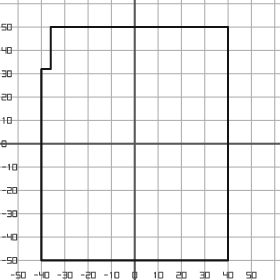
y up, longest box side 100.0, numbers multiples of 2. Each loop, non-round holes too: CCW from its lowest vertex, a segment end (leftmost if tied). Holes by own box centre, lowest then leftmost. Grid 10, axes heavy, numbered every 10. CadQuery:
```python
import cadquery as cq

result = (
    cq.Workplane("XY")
    .moveTo(-40.0, -50.0)
    .lineTo(40.0, -50.0)
    .lineTo(40.0, 50.0)
    .lineTo(-36.0, 50.0)
    .lineTo(-36.0, 32.0)
    .lineTo(-40.0, 32.0)
    .close()
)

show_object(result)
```